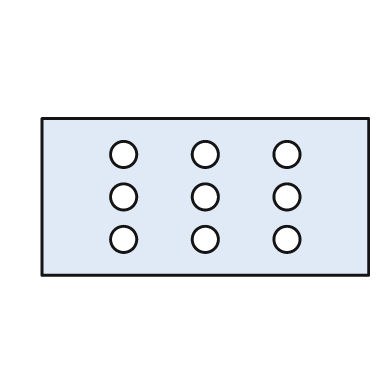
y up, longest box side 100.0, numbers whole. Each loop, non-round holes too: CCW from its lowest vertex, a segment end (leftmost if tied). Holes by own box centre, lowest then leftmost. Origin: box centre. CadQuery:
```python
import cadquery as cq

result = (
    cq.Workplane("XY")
    .moveTo(-50.0, -24.0)
    .lineTo(50.0, -24.0)
    .lineTo(50.0, 24.0)
    .lineTo(-50.0, 24.0)
    .close()
    .moveTo(-25.0, -13.0)
    .circle(4.0)
    .moveTo(0.0, -13.0)
    .circle(4.0)
    .moveTo(25.0, -13.0)
    .circle(4.0)
    .moveTo(-25.0, 0.0)
    .circle(4.0)
    .moveTo(0.0, 0.0)
    .circle(4.0)
    .moveTo(25.0, 0.0)
    .circle(4.0)
    .moveTo(-25.0, 13.0)
    .circle(4.0)
    .moveTo(0.0, 13.0)
    .circle(4.0)
    .moveTo(25.0, 13.0)
    .circle(4.0)
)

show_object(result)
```